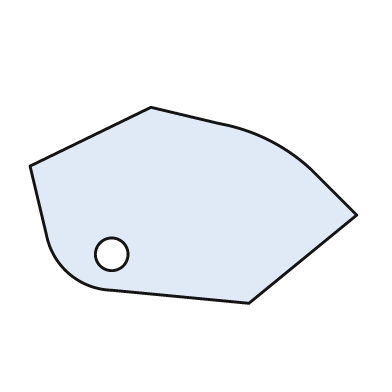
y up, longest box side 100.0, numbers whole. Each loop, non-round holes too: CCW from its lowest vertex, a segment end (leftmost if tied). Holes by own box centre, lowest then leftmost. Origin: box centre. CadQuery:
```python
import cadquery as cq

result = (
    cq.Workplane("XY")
    .moveTo(17.0, -30.0)
    .lineTo(50.0, -3.0)
    .lineTo(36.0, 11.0)
    .threePointArc((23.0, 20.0), (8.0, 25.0))
    .lineTo(-13.0, 30.0)
    .lineTo(-50.0, 12.0)
    .lineTo(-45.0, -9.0)
    .threePointArc((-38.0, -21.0), (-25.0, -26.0))
    .close()
    .moveTo(-25.0, -15.0)
    .circle(5.0)
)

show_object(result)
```